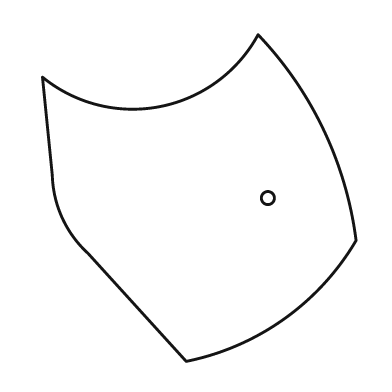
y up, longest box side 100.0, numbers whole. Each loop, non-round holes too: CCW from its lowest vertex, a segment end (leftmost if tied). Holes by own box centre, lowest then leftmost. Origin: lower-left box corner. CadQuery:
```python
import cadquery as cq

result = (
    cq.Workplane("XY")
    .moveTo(44.0, 0.0)
    .threePointArc((74.0, 13.0), (96.0, 37.0))
    .threePointArc((86.0, 71.0), (66.0, 100.0))
    .threePointArc((36.0, 78.0), (0.0, 87.0))
    .lineTo(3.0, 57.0)
    .threePointArc((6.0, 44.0), (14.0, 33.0))
    .close()
    .moveTo(69.0, 50.0)
    .circle(2.0)
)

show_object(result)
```